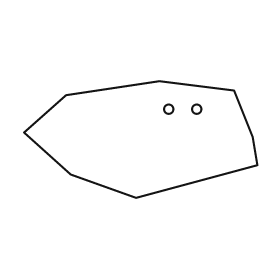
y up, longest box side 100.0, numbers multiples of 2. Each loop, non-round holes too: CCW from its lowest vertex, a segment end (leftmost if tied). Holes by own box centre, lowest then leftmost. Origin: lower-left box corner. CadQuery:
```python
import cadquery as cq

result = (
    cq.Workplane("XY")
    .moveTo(48.0, 0.0)
    .lineTo(100.0, 14.0)
    .lineTo(98.0, 26.0)
    .lineTo(90.0, 46.0)
    .lineTo(58.0, 50.0)
    .lineTo(18.0, 44.0)
    .lineTo(0.0, 28.0)
    .lineTo(20.0, 10.0)
    .close()
    .moveTo(62.0, 38.0)
    .circle(2.0)
    .moveTo(74.0, 38.0)
    .circle(2.0)
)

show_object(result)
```